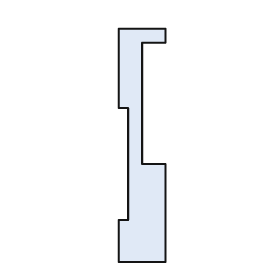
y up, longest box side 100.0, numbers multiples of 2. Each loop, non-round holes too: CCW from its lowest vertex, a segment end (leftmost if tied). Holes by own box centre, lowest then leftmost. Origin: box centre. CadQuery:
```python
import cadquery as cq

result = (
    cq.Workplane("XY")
    .moveTo(-10.0, -50.0)
    .lineTo(10.0, -50.0)
    .lineTo(10.0, -8.0)
    .lineTo(0.0, -8.0)
    .lineTo(0.0, 44.0)
    .lineTo(10.0, 44.0)
    .lineTo(10.0, 50.0)
    .lineTo(-10.0, 50.0)
    .lineTo(-10.0, 16.0)
    .lineTo(-6.0, 16.0)
    .lineTo(-6.0, -32.0)
    .lineTo(-10.0, -32.0)
    .close()
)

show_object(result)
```